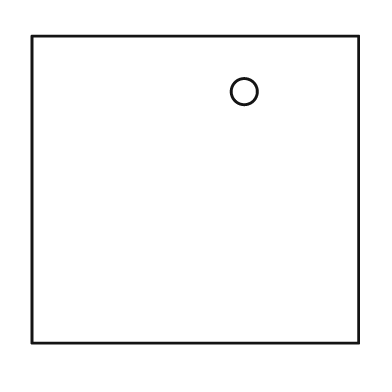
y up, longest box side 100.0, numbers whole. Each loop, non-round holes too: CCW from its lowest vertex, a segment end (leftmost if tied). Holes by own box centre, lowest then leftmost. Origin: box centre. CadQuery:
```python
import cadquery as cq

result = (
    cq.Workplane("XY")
    .moveTo(-50.0, -47.0)
    .lineTo(50.0, -47.0)
    .lineTo(50.0, 47.0)
    .lineTo(-50.0, 47.0)
    .close()
    .moveTo(15.0, 30.0)
    .circle(4.0)
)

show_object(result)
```